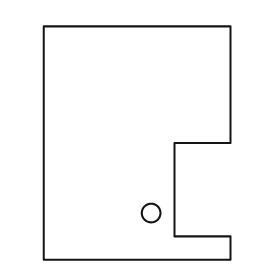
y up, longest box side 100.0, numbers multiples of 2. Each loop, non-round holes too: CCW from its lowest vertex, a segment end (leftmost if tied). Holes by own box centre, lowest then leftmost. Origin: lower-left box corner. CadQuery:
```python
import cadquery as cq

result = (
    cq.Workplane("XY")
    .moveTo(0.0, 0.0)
    .lineTo(80.0, 0.0)
    .lineTo(80.0, 10.0)
    .lineTo(56.0, 10.0)
    .lineTo(56.0, 50.0)
    .lineTo(80.0, 50.0)
    .lineTo(80.0, 100.0)
    .lineTo(0.0, 100.0)
    .close()
    .moveTo(46.0, 20.0)
    .circle(4.0)
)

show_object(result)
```